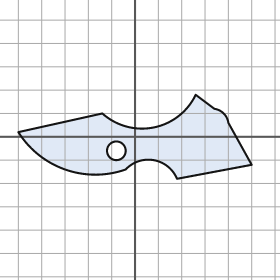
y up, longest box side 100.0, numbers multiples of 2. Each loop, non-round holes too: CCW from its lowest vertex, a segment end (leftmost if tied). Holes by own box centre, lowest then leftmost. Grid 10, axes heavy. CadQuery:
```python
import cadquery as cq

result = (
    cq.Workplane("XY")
    .moveTo(18.0, -18.0)
    .lineTo(50.0, -12.0)
    .lineTo(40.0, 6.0)
    .threePointArc((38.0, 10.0), (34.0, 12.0))
    .lineTo(26.0, 18.0)
    .threePointArc((8.0, 4.0), (-14.0, 10.0))
    .lineTo(-50.0, 2.0)
    .threePointArc((-30.0, -14.0), (-4.0, -14.0))
    .threePointArc((8.0, -10.0), (18.0, -18.0))
    .close()
    .moveTo(-8.0, -6.0)
    .circle(4.0)
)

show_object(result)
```